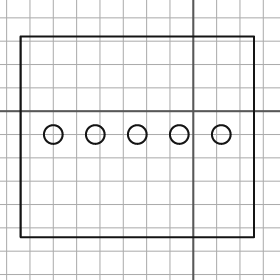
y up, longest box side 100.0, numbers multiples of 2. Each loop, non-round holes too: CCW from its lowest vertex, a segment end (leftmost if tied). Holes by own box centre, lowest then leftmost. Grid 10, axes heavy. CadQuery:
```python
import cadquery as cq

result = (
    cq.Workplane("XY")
    .moveTo(-74.0, -54.0)
    .lineTo(26.0, -54.0)
    .lineTo(26.0, 32.0)
    .lineTo(-74.0, 32.0)
    .close()
    .moveTo(-60.0, -10.0)
    .circle(4.0)
    .moveTo(-42.0, -10.0)
    .circle(4.0)
    .moveTo(-24.0, -10.0)
    .circle(4.0)
    .moveTo(-6.0, -10.0)
    .circle(4.0)
    .moveTo(12.0, -10.0)
    .circle(4.0)
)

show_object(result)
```